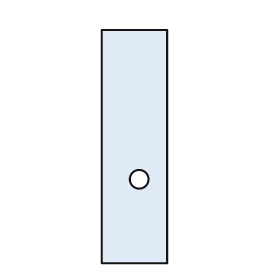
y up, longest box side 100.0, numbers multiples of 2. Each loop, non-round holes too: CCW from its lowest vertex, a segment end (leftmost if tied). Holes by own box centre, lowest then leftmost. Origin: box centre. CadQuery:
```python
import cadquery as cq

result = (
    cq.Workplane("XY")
    .moveTo(-14.0, -50.0)
    .lineTo(14.0, -50.0)
    .lineTo(14.0, 50.0)
    .lineTo(-14.0, 50.0)
    .close()
    .moveTo(2.0, -14.0)
    .circle(4.0)
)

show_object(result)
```